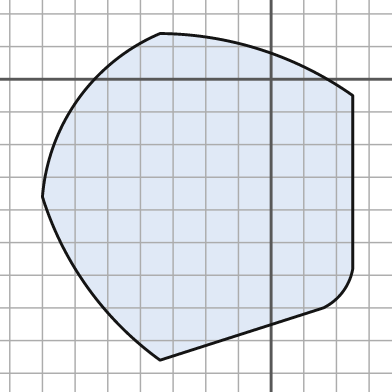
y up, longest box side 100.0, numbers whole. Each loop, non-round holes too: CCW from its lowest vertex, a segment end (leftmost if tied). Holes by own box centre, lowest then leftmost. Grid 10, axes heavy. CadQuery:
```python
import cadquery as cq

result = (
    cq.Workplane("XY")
    .moveTo(-34.0, -86.0)
    .lineTo(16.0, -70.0)
    .threePointArc((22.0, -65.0), (25.0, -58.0))
    .lineTo(25.0, -5.0)
    .threePointArc((-3.0, 9.0), (-34.0, 14.0))
    .threePointArc((-59.0, -6.0), (-70.0, -36.0))
    .threePointArc((-56.0, -64.0), (-34.0, -86.0))
    .close()
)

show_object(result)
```